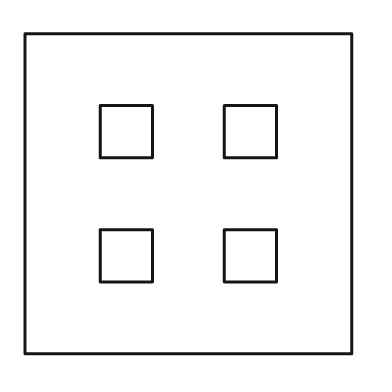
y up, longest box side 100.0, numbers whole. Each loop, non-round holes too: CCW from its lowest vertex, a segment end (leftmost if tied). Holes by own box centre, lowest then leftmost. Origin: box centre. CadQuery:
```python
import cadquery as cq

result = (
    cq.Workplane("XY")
    .moveTo(-50.0, -49.0)
    .lineTo(50.0, -49.0)
    .lineTo(50.0, 49.0)
    .lineTo(-50.0, 49.0)
    .close()
    .moveTo(-27.0, -27.0)
    .lineTo(-11.0, -27.0)
    .lineTo(-11.0, -11.0)
    .lineTo(-27.0, -11.0)
    .close()
    .moveTo(11.0, -27.0)
    .lineTo(27.0, -27.0)
    .lineTo(27.0, -11.0)
    .lineTo(11.0, -11.0)
    .close()
    .moveTo(-27.0, 11.0)
    .lineTo(-11.0, 11.0)
    .lineTo(-11.0, 27.0)
    .lineTo(-27.0, 27.0)
    .close()
    .moveTo(11.0, 11.0)
    .lineTo(27.0, 11.0)
    .lineTo(27.0, 27.0)
    .lineTo(11.0, 27.0)
    .close()
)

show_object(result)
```